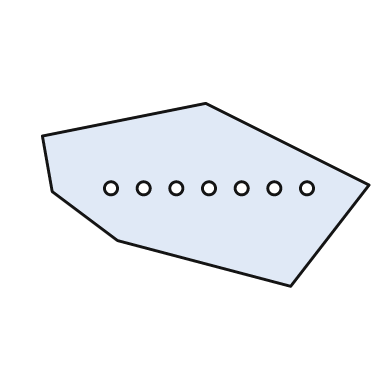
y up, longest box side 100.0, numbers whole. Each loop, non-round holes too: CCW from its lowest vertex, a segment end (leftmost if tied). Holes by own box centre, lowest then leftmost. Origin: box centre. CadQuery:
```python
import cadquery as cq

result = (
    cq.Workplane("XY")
    .moveTo(26.0, -28.0)
    .lineTo(50.0, 3.0)
    .lineTo(0.0, 28.0)
    .lineTo(-50.0, 18.0)
    .lineTo(-47.0, 1.0)
    .lineTo(-27.0, -14.0)
    .close()
    .moveTo(-29.0, 2.0)
    .circle(2.0)
    .moveTo(-19.0, 2.0)
    .circle(2.0)
    .moveTo(-9.0, 2.0)
    .circle(2.0)
    .moveTo(1.0, 2.0)
    .circle(2.0)
    .moveTo(11.0, 2.0)
    .circle(2.0)
    .moveTo(21.0, 2.0)
    .circle(2.0)
    .moveTo(31.0, 2.0)
    .circle(2.0)
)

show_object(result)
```